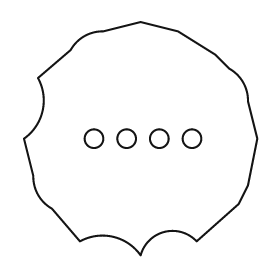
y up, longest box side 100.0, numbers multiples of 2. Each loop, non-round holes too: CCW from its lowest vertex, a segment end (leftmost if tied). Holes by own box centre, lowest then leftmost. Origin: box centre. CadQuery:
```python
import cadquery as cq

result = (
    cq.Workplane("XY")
    .moveTo(0.0, -50.0)
    .threePointArc((10.0, -40.0), (24.0, -44.0))
    .lineTo(42.0, -28.0)
    .lineTo(46.0, -20.0)
    .lineTo(50.0, 0.0)
    .lineTo(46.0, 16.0)
    .threePointArc((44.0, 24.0), (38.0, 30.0))
    .lineTo(32.0, 36.0)
    .lineTo(16.0, 46.0)
    .lineTo(0.0, 50.0)
    .lineTo(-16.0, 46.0)
    .threePointArc((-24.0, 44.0), (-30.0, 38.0))
    .lineTo(-44.0, 26.0)
    .threePointArc((-42.0, 12.0), (-50.0, 0.0))
    .lineTo(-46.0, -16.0)
    .threePointArc((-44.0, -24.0), (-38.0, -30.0))
    .lineTo(-26.0, -44.0)
    .threePointArc((-12.0, -42.0), (0.0, -50.0))
    .close()
    .moveTo(-20.0, 0.0)
    .circle(4.0)
    .moveTo(-6.0, 0.0)
    .circle(4.0)
    .moveTo(8.0, 0.0)
    .circle(4.0)
    .moveTo(22.0, 0.0)
    .circle(4.0)
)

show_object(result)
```